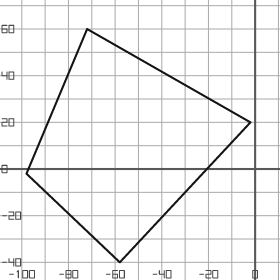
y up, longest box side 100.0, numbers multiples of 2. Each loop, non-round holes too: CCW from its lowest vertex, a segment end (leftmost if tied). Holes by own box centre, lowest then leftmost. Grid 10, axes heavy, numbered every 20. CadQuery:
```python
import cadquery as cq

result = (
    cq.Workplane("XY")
    .moveTo(-58.0, -40.0)
    .lineTo(-2.0, 20.0)
    .lineTo(-72.0, 60.0)
    .lineTo(-98.0, -2.0)
    .close()
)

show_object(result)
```